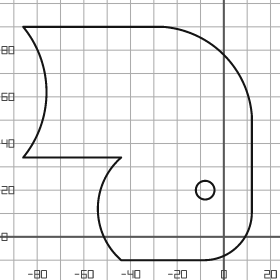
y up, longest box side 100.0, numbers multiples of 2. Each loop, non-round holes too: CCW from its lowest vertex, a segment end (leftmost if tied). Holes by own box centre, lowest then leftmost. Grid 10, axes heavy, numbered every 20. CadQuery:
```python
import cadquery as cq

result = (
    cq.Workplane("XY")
    .moveTo(-44.0, -10.0)
    .lineTo(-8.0, -10.0)
    .threePointArc((6.0, -4.0), (12.0, 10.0))
    .lineTo(12.0, 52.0)
    .threePointArc((0.0, 78.0), (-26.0, 90.0))
    .lineTo(-86.0, 90.0)
    .threePointArc((-76.0, 62.0), (-86.0, 34.0))
    .lineTo(-44.0, 34.0)
    .threePointArc((-54.0, 12.0), (-44.0, -10.0))
    .close()
    .moveTo(-8.0, 20.0)
    .circle(4.0)
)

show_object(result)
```